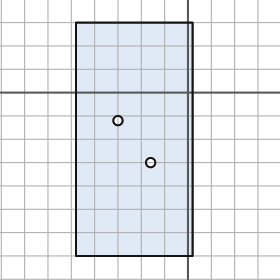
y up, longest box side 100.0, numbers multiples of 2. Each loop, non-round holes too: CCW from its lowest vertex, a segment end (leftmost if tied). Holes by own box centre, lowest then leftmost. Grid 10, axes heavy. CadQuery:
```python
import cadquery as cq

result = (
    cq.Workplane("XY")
    .moveTo(-48.0, -70.0)
    .lineTo(2.0, -70.0)
    .lineTo(2.0, 30.0)
    .lineTo(-48.0, 30.0)
    .close()
    .moveTo(-16.0, -30.0)
    .circle(2.0)
    .moveTo(-30.0, -12.0)
    .circle(2.0)
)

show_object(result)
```